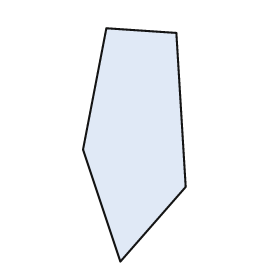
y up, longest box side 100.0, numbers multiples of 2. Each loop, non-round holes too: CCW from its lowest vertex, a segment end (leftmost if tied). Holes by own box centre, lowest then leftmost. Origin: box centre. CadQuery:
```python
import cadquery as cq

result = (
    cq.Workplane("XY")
    .moveTo(-6.0, -50.0)
    .lineTo(22.0, -18.0)
    .lineTo(18.0, 48.0)
    .lineTo(-12.0, 50.0)
    .lineTo(-22.0, -2.0)
    .close()
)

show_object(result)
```